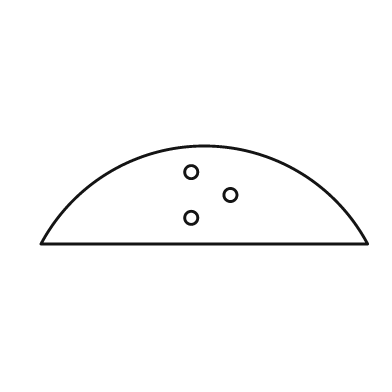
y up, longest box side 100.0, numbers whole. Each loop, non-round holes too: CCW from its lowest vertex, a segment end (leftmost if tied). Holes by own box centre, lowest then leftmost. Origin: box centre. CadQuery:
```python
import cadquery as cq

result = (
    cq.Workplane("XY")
    .moveTo(-50.0, -15.0)
    .lineTo(50.0, -15.0)
    .threePointArc((0.0, 15.0), (-50.0, -15.0))
    .close()
    .moveTo(-4.0, -7.0)
    .circle(2.0)
    .moveTo(8.0, 0.0)
    .circle(2.0)
    .moveTo(-4.0, 7.0)
    .circle(2.0)
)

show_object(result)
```